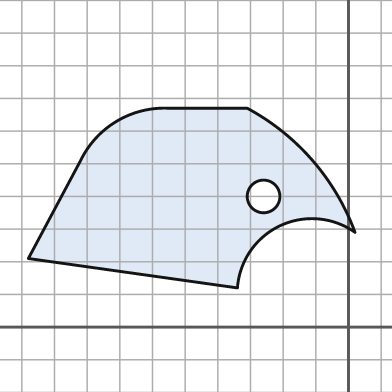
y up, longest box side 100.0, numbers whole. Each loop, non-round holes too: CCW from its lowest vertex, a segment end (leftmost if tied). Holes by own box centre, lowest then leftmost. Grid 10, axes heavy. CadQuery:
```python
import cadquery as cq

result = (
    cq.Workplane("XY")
    .moveTo(-34.0, 12.0)
    .threePointArc((-21.0, 31.0), (2.0, 29.0))
    .threePointArc((-11.0, 51.0), (-31.0, 67.0))
    .lineTo(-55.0, 67.0)
    .threePointArc((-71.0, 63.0), (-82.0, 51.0))
    .lineTo(-98.0, 21.0)
    .close()
    .moveTo(-26.0, 40.0)
    .circle(5.0)
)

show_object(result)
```